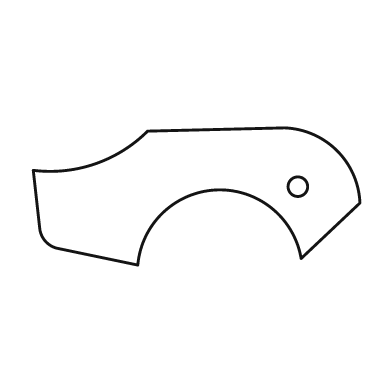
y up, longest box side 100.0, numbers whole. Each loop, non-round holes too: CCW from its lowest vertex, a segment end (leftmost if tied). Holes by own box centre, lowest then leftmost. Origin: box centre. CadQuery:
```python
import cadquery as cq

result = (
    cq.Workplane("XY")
    .moveTo(-18.0, -21.0)
    .threePointArc((6.0, 2.0), (32.0, -19.0))
    .lineTo(50.0, -2.0)
    .threePointArc((43.0, 14.0), (27.0, 21.0))
    .lineTo(-15.0, 20.0)
    .threePointArc((-31.0, 10.0), (-50.0, 8.0))
    .lineTo(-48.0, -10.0)
    .threePointArc((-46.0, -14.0), (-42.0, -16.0))
    .close()
    .moveTo(31.0, 3.0)
    .circle(3.0)
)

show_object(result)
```